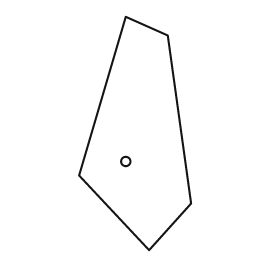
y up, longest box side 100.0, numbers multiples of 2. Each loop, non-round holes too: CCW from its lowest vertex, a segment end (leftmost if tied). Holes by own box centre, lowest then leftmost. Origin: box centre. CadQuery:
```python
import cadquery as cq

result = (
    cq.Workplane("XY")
    .moveTo(6.0, -50.0)
    .lineTo(24.0, -30.0)
    .lineTo(14.0, 42.0)
    .lineTo(-4.0, 50.0)
    .lineTo(-24.0, -18.0)
    .close()
    .moveTo(-4.0, -12.0)
    .circle(2.0)
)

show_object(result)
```